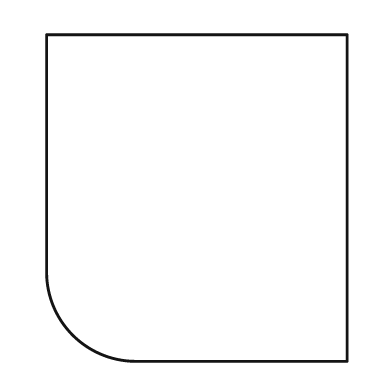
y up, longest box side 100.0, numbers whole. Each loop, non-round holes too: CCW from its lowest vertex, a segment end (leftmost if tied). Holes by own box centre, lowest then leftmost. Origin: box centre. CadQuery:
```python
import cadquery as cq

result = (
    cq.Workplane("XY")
    .moveTo(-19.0, -50.0)
    .lineTo(46.0, -50.0)
    .lineTo(46.0, 50.0)
    .lineTo(-46.0, 50.0)
    .lineTo(-46.0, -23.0)
    .threePointArc((-38.0, -42.0), (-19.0, -50.0))
    .close()
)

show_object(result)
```